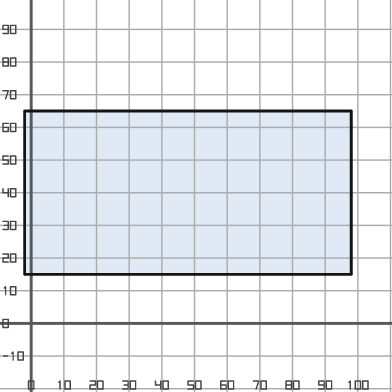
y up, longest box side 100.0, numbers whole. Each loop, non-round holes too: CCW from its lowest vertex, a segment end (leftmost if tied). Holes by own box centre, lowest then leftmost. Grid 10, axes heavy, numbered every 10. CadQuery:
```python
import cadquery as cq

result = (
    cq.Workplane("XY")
    .moveTo(-2.0, 15.0)
    .lineTo(98.0, 15.0)
    .lineTo(98.0, 65.0)
    .lineTo(-2.0, 65.0)
    .close()
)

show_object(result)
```